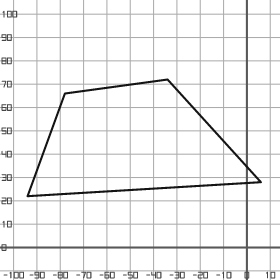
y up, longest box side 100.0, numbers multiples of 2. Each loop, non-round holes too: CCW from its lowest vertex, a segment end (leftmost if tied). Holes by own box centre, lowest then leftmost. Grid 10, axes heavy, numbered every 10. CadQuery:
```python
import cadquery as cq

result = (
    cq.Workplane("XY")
    .moveTo(-94.0, 22.0)
    .lineTo(6.0, 28.0)
    .lineTo(-34.0, 72.0)
    .lineTo(-78.0, 66.0)
    .close()
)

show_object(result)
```